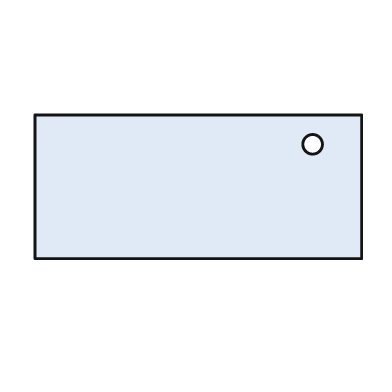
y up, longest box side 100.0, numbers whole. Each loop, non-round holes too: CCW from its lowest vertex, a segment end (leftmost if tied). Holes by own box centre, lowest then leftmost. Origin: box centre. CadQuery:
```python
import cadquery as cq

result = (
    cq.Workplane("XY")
    .moveTo(-50.0, -22.0)
    .lineTo(50.0, -22.0)
    .lineTo(50.0, 22.0)
    .lineTo(-50.0, 22.0)
    .close()
    .moveTo(35.0, 13.0)
    .circle(3.0)
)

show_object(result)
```